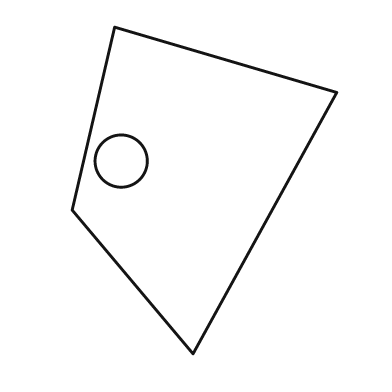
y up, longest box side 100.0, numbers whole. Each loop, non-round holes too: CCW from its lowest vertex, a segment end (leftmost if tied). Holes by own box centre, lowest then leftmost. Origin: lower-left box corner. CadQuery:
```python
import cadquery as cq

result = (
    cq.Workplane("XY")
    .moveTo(37.0, 0.0)
    .lineTo(81.0, 80.0)
    .lineTo(13.0, 100.0)
    .lineTo(0.0, 44.0)
    .close()
    .moveTo(15.0, 59.0)
    .circle(8.0)
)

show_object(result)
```